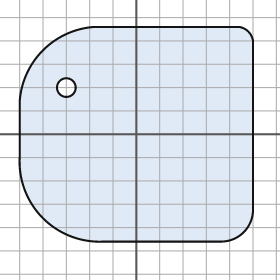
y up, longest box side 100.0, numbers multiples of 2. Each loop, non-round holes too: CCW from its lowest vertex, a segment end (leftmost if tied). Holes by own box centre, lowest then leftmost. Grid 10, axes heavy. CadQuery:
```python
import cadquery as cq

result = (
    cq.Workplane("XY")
    .moveTo(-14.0, -46.0)
    .lineTo(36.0, -46.0)
    .threePointArc((46.0, -42.0), (50.0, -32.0))
    .lineTo(50.0, 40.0)
    .threePointArc((48.0, 44.0), (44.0, 46.0))
    .lineTo(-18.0, 46.0)
    .threePointArc((-40.0, 36.0), (-50.0, 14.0))
    .lineTo(-50.0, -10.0)
    .threePointArc((-40.0, -36.0), (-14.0, -46.0))
    .close()
    .moveTo(-30.0, 20.0)
    .circle(4.0)
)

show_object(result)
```